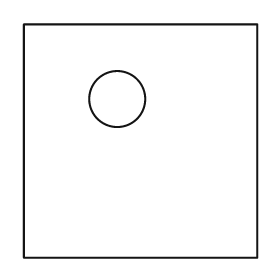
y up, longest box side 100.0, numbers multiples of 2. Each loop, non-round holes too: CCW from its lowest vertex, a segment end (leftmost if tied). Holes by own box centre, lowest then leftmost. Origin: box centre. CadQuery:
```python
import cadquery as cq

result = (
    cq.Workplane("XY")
    .moveTo(-50.0, -50.0)
    .lineTo(50.0, -50.0)
    .lineTo(50.0, 50.0)
    .lineTo(-50.0, 50.0)
    .close()
    .moveTo(-10.0, 18.0)
    .circle(12.0)
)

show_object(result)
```